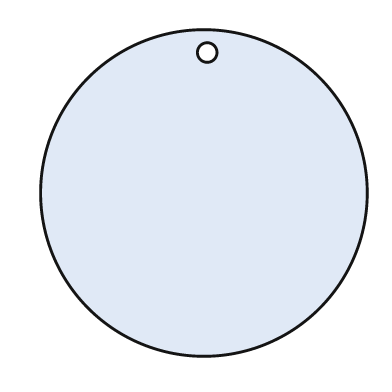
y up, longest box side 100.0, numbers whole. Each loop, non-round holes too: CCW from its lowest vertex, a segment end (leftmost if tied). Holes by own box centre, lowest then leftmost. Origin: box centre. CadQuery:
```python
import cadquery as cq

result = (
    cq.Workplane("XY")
    .moveTo(0.0, 0.0)
    .circle(50.0)
    .moveTo(1.0, 43.0)
    .circle(3.0)
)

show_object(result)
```